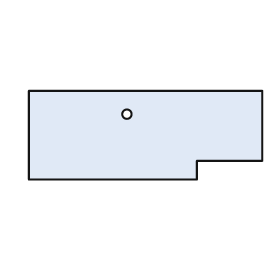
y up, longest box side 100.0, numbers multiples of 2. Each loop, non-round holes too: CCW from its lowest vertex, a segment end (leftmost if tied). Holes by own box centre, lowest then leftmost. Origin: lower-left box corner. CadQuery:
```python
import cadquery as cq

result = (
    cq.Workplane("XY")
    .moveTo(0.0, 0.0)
    .lineTo(72.0, 0.0)
    .lineTo(72.0, 8.0)
    .lineTo(100.0, 8.0)
    .lineTo(100.0, 38.0)
    .lineTo(0.0, 38.0)
    .close()
    .moveTo(42.0, 28.0)
    .circle(2.0)
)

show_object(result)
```